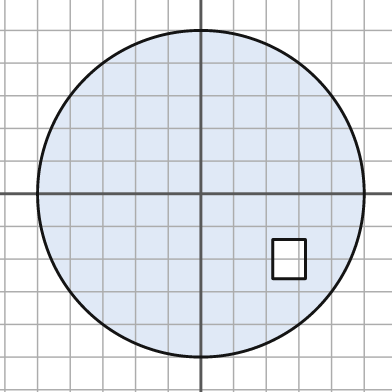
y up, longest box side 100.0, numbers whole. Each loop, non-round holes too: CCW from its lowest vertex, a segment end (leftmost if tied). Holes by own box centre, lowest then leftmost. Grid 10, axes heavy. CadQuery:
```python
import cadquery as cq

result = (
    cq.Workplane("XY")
    .moveTo(0.0, 0.0)
    .circle(50.0)
    .moveTo(22.0, -26.0)
    .lineTo(32.0, -26.0)
    .lineTo(32.0, -14.0)
    .lineTo(22.0, -14.0)
    .close()
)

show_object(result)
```